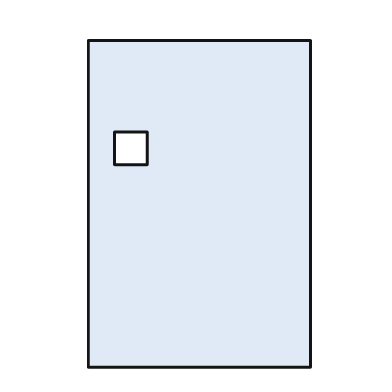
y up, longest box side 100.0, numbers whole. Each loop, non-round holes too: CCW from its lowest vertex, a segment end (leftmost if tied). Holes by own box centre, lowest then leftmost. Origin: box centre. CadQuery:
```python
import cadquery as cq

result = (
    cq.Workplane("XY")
    .moveTo(-34.0, -50.0)
    .lineTo(34.0, -50.0)
    .lineTo(34.0, 50.0)
    .lineTo(-34.0, 50.0)
    .close()
    .moveTo(-26.0, 12.0)
    .lineTo(-16.0, 12.0)
    .lineTo(-16.0, 22.0)
    .lineTo(-26.0, 22.0)
    .close()
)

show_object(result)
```